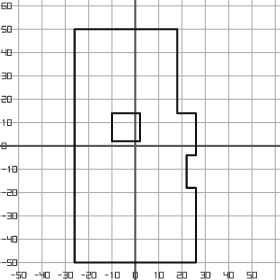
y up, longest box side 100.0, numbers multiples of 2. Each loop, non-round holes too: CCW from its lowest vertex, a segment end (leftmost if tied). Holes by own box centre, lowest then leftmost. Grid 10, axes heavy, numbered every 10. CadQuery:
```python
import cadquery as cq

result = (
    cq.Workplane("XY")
    .moveTo(-26.0, -50.0)
    .lineTo(26.0, -50.0)
    .lineTo(26.0, -18.0)
    .lineTo(22.0, -18.0)
    .lineTo(22.0, -4.0)
    .lineTo(26.0, -4.0)
    .lineTo(26.0, 14.0)
    .lineTo(18.0, 14.0)
    .lineTo(18.0, 50.0)
    .lineTo(-26.0, 50.0)
    .close()
    .moveTo(-10.0, 2.0)
    .lineTo(2.0, 2.0)
    .lineTo(2.0, 14.0)
    .lineTo(-10.0, 14.0)
    .close()
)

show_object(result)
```